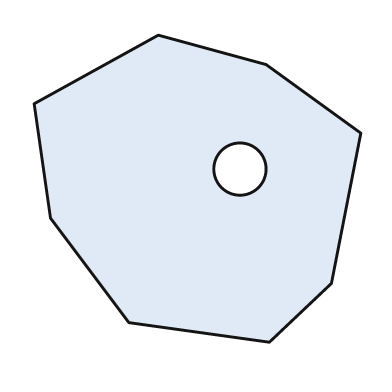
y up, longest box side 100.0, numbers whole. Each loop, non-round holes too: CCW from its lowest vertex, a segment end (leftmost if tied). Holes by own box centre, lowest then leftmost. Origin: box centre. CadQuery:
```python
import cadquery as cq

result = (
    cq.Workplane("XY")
    .moveTo(22.0, -47.0)
    .lineTo(41.0, -29.0)
    .lineTo(50.0, 17.0)
    .lineTo(21.0, 38.0)
    .lineTo(-12.0, 47.0)
    .lineTo(-50.0, 26.0)
    .lineTo(-45.0, -9.0)
    .lineTo(-21.0, -41.0)
    .close()
    .moveTo(13.0, 6.0)
    .circle(8.0)
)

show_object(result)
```